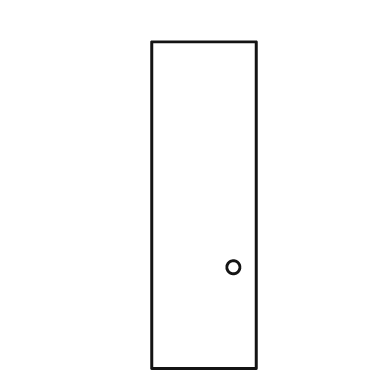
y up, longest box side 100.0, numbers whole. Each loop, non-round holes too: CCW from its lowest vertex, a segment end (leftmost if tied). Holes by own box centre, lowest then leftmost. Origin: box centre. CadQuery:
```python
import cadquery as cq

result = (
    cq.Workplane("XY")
    .moveTo(-16.0, -50.0)
    .lineTo(16.0, -50.0)
    .lineTo(16.0, 50.0)
    .lineTo(-16.0, 50.0)
    .close()
    .moveTo(9.0, -19.0)
    .circle(2.0)
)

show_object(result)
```